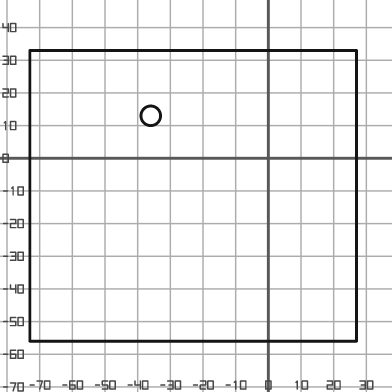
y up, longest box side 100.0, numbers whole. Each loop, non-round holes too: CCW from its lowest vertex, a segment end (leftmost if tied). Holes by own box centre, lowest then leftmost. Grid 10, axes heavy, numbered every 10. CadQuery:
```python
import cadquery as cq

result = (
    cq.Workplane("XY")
    .moveTo(-73.0, -56.0)
    .lineTo(27.0, -56.0)
    .lineTo(27.0, 33.0)
    .lineTo(-73.0, 33.0)
    .close()
    .moveTo(-36.0, 13.0)
    .circle(3.0)
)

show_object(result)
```